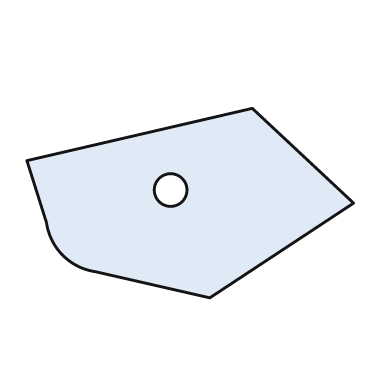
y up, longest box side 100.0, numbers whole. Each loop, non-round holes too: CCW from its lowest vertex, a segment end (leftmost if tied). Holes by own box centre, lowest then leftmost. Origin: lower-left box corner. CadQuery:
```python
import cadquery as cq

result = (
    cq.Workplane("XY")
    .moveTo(56.0, 0.0)
    .lineTo(100.0, 29.0)
    .lineTo(69.0, 58.0)
    .lineTo(0.0, 42.0)
    .lineTo(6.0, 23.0)
    .threePointArc((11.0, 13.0), (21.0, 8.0))
    .close()
    .moveTo(44.0, 33.0)
    .circle(5.0)
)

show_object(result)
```